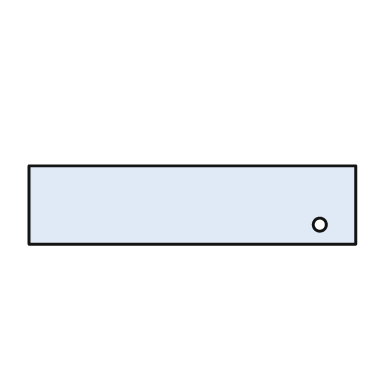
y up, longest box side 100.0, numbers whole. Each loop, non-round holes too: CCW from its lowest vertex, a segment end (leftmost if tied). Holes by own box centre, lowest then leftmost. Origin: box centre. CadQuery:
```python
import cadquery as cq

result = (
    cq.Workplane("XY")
    .moveTo(-50.0, -12.0)
    .lineTo(50.0, -12.0)
    .lineTo(50.0, 12.0)
    .lineTo(-50.0, 12.0)
    .close()
    .moveTo(39.0, -6.0)
    .circle(2.0)
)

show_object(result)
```